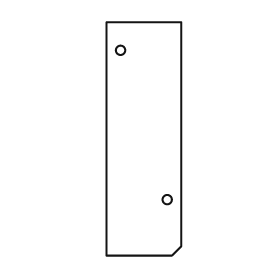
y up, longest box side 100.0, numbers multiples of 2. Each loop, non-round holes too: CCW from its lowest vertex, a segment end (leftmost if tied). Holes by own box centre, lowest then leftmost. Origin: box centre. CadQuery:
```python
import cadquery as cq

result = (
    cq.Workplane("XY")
    .moveTo(-16.0, -50.0)
    .lineTo(12.0, -50.0)
    .lineTo(16.0, -46.0)
    .lineTo(16.0, 50.0)
    .lineTo(-16.0, 50.0)
    .close()
    .moveTo(10.0, -26.0)
    .circle(2.0)
    .moveTo(-10.0, 38.0)
    .circle(2.0)
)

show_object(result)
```